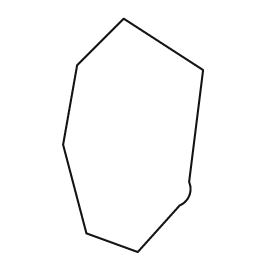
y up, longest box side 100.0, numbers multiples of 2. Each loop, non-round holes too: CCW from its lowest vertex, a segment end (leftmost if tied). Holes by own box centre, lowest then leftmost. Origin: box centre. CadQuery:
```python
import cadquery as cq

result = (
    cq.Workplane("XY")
    .moveTo(2.0, -50.0)
    .lineTo(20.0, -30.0)
    .threePointArc((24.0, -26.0), (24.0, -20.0))
    .lineTo(30.0, 28.0)
    .lineTo(-4.0, 50.0)
    .lineTo(-24.0, 30.0)
    .lineTo(-30.0, -4.0)
    .lineTo(-20.0, -42.0)
    .close()
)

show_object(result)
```